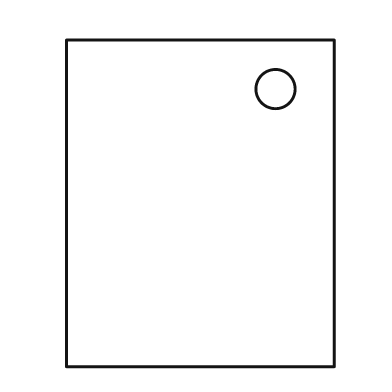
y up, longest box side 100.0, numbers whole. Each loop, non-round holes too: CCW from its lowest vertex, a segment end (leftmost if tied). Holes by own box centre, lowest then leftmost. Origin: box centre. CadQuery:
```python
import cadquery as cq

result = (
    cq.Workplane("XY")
    .moveTo(-41.0, -50.0)
    .lineTo(41.0, -50.0)
    .lineTo(41.0, 50.0)
    .lineTo(-41.0, 50.0)
    .close()
    .moveTo(23.0, 35.0)
    .circle(6.0)
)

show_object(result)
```